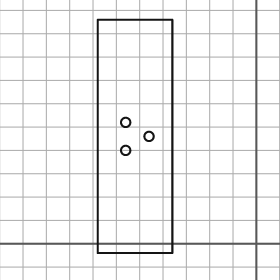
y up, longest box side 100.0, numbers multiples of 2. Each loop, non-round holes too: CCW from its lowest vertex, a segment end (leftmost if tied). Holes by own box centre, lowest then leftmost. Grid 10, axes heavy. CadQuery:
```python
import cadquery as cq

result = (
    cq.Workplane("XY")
    .moveTo(-68.0, -4.0)
    .lineTo(-36.0, -4.0)
    .lineTo(-36.0, 96.0)
    .lineTo(-68.0, 96.0)
    .close()
    .moveTo(-56.0, 40.0)
    .circle(2.0)
    .moveTo(-46.0, 46.0)
    .circle(2.0)
    .moveTo(-56.0, 52.0)
    .circle(2.0)
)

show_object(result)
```